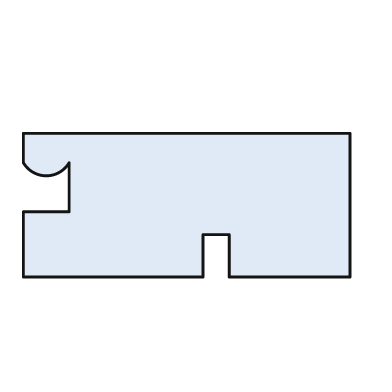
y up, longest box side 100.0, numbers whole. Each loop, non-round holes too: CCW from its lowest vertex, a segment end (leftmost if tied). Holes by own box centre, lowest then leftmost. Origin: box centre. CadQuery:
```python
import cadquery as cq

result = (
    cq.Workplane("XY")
    .moveTo(-50.0, -22.0)
    .lineTo(5.0, -22.0)
    .lineTo(5.0, -9.0)
    .lineTo(13.0, -9.0)
    .lineTo(13.0, -22.0)
    .lineTo(50.0, -22.0)
    .lineTo(50.0, 22.0)
    .lineTo(-50.0, 22.0)
    .lineTo(-50.0, 13.0)
    .threePointArc((-43.0, 9.0), (-36.0, 13.0))
    .lineTo(-36.0, -2.0)
    .lineTo(-50.0, -2.0)
    .close()
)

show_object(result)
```